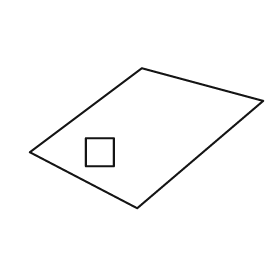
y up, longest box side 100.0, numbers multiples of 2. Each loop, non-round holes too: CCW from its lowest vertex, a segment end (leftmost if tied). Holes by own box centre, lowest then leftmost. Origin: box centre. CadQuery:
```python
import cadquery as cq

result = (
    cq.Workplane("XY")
    .moveTo(-4.0, -30.0)
    .lineTo(50.0, 16.0)
    .lineTo(-2.0, 30.0)
    .lineTo(-50.0, -6.0)
    .close()
    .moveTo(-26.0, -12.0)
    .lineTo(-14.0, -12.0)
    .lineTo(-14.0, 0.0)
    .lineTo(-26.0, 0.0)
    .close()
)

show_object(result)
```